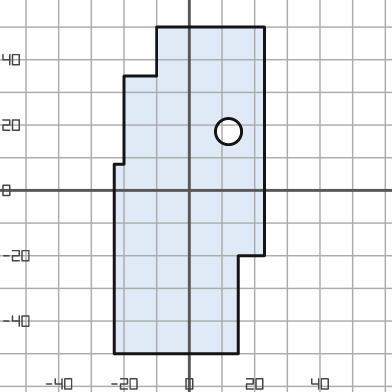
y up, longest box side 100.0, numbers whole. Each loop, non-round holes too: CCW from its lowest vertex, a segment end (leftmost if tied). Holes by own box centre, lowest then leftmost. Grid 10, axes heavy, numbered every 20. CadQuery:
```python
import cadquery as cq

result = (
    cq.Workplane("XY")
    .moveTo(-23.0, -50.0)
    .lineTo(15.0, -50.0)
    .lineTo(15.0, -20.0)
    .lineTo(23.0, -20.0)
    .lineTo(23.0, 50.0)
    .lineTo(-10.0, 50.0)
    .lineTo(-10.0, 35.0)
    .lineTo(-20.0, 35.0)
    .lineTo(-20.0, 8.0)
    .lineTo(-23.0, 8.0)
    .close()
    .moveTo(12.0, 18.0)
    .circle(4.0)
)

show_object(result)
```